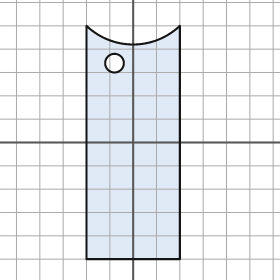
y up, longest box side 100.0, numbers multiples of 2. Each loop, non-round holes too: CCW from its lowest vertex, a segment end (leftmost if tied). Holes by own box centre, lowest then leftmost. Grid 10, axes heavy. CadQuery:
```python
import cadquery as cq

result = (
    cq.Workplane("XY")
    .moveTo(-20.0, -50.0)
    .lineTo(20.0, -50.0)
    .lineTo(20.0, 50.0)
    .threePointArc((0.0, 42.0), (-20.0, 50.0))
    .close()
    .moveTo(-8.0, 34.0)
    .circle(4.0)
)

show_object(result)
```